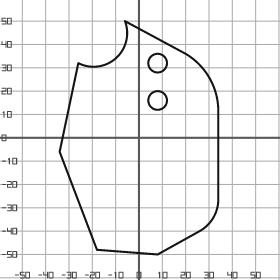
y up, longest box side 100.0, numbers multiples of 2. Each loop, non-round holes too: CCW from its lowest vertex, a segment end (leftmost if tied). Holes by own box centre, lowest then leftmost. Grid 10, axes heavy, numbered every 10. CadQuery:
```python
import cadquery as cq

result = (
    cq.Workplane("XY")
    .moveTo(8.0, -50.0)
    .lineTo(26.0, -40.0)
    .threePointArc((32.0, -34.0), (34.0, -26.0))
    .lineTo(34.0, 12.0)
    .threePointArc((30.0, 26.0), (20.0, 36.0))
    .lineTo(-6.0, 50.0)
    .threePointArc((-10.0, 34.0), (-26.0, 32.0))
    .lineTo(-34.0, -6.0)
    .lineTo(-18.0, -48.0)
    .close()
    .moveTo(8.0, 16.0)
    .circle(4.0)
    .moveTo(8.0, 32.0)
    .circle(4.0)
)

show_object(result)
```